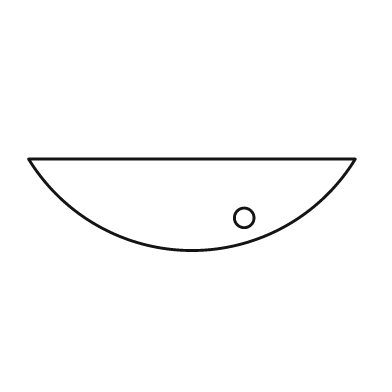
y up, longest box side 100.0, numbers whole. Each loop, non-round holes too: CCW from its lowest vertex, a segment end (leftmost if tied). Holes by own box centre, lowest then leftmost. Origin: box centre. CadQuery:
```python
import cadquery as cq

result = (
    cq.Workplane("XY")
    .moveTo(-50.0, 14.0)
    .threePointArc((0.0, -14.0), (50.0, 14.0))
    .close()
    .moveTo(16.0, -4.0)
    .circle(3.0)
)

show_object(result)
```